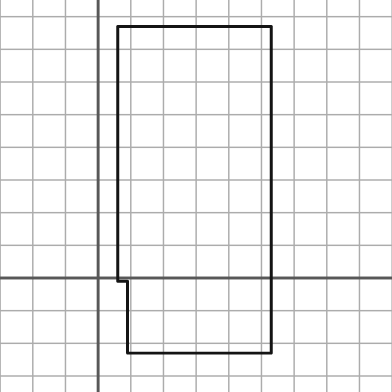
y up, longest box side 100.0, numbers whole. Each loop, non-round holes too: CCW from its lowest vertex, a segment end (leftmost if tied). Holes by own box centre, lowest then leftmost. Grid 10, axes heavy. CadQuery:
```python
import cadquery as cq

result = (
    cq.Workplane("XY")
    .moveTo(9.0, -23.0)
    .lineTo(53.0, -23.0)
    .lineTo(53.0, 77.0)
    .lineTo(6.0, 77.0)
    .lineTo(6.0, -1.0)
    .lineTo(9.0, -1.0)
    .close()
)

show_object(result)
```